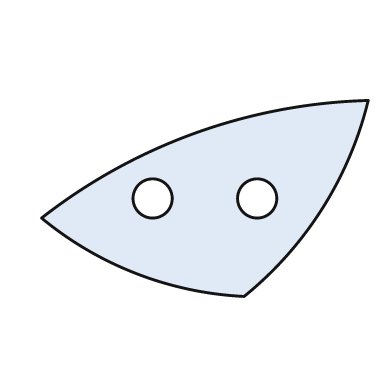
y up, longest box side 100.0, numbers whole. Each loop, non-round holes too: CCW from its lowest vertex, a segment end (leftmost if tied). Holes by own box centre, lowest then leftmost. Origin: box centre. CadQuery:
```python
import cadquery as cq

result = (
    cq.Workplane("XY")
    .moveTo(12.0, -30.0)
    .threePointArc((36.0, -3.0), (50.0, 30.0))
    .threePointArc((-3.0, 20.0), (-50.0, -6.0))
    .threePointArc((-21.0, -23.0), (12.0, -30.0))
    .close()
    .moveTo(-16.0, 0.0)
    .circle(6.0)
    .moveTo(16.0, 0.0)
    .circle(6.0)
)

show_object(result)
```